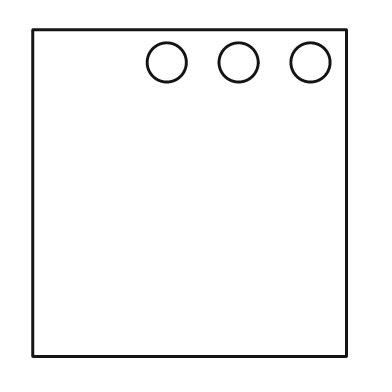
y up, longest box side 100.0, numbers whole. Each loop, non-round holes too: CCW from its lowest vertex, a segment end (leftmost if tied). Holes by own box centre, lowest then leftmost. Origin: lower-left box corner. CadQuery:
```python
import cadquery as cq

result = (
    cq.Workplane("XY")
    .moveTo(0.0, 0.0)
    .lineTo(96.0, 0.0)
    .lineTo(96.0, 100.0)
    .lineTo(0.0, 100.0)
    .close()
    .moveTo(41.0, 90.0)
    .circle(6.0)
    .moveTo(63.0, 90.0)
    .circle(6.0)
    .moveTo(85.0, 90.0)
    .circle(6.0)
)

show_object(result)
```